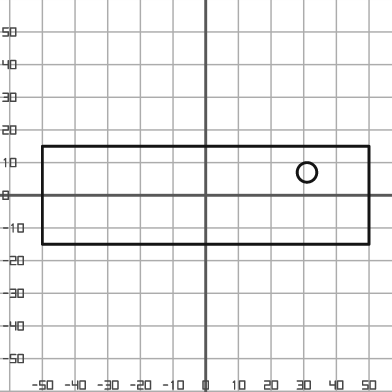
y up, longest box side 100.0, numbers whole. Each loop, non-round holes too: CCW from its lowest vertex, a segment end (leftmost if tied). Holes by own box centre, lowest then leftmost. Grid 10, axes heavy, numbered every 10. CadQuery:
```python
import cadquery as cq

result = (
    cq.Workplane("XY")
    .moveTo(-50.0, -15.0)
    .lineTo(50.0, -15.0)
    .lineTo(50.0, 15.0)
    .lineTo(-50.0, 15.0)
    .close()
    .moveTo(31.0, 7.0)
    .circle(3.0)
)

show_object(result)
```